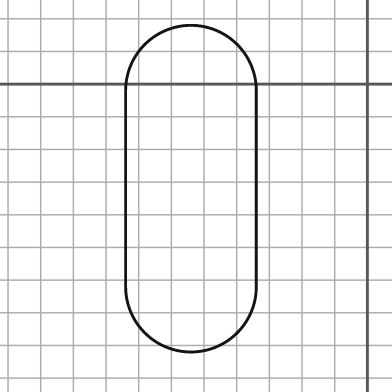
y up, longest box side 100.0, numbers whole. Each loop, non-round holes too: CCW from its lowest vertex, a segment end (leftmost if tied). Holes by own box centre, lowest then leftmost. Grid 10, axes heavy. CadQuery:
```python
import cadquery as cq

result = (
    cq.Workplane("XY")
    .moveTo(-74.0, -62.0)
    .threePointArc((-54.0, -82.0), (-34.0, -62.0))
    .lineTo(-34.0, -2.0)
    .threePointArc((-54.0, 18.0), (-74.0, -2.0))
    .close()
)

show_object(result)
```